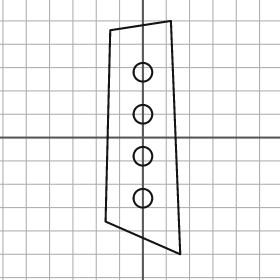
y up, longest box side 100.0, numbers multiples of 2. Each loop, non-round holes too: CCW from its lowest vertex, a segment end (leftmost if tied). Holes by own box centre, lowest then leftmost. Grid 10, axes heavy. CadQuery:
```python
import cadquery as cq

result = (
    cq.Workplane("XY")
    .moveTo(16.0, -50.0)
    .lineTo(12.0, 50.0)
    .lineTo(-14.0, 46.0)
    .lineTo(-16.0, -36.0)
    .close()
    .moveTo(0.0, -26.0)
    .circle(4.0)
    .moveTo(0.0, -8.0)
    .circle(4.0)
    .moveTo(0.0, 10.0)
    .circle(4.0)
    .moveTo(0.0, 28.0)
    .circle(4.0)
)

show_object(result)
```